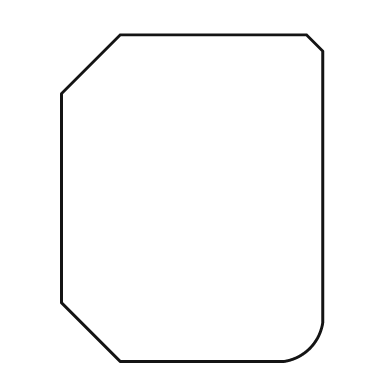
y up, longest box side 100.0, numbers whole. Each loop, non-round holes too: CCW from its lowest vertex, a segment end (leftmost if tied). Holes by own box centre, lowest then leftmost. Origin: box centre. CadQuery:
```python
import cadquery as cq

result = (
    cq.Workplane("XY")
    .moveTo(-22.0, -50.0)
    .lineTo(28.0, -50.0)
    .threePointArc((36.0, -46.0), (40.0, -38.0))
    .lineTo(40.0, 45.0)
    .lineTo(35.0, 50.0)
    .lineTo(-22.0, 50.0)
    .lineTo(-40.0, 32.0)
    .lineTo(-40.0, -32.0)
    .close()
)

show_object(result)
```